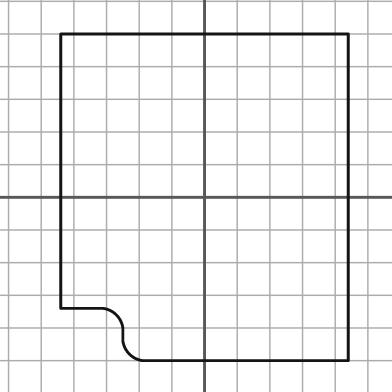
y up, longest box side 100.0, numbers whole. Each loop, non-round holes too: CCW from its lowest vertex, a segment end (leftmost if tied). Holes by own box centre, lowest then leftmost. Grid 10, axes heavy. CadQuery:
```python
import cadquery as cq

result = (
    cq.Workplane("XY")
    .moveTo(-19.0, -50.0)
    .lineTo(44.0, -50.0)
    .lineTo(44.0, 50.0)
    .lineTo(-44.0, 50.0)
    .lineTo(-44.0, -34.0)
    .lineTo(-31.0, -34.0)
    .threePointArc((-27.0, -36.0), (-25.0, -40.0))
    .lineTo(-25.0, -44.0)
    .threePointArc((-23.0, -48.0), (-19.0, -50.0))
    .close()
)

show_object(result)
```